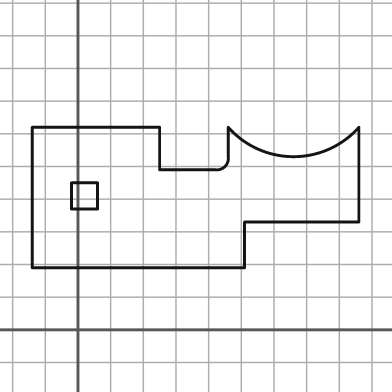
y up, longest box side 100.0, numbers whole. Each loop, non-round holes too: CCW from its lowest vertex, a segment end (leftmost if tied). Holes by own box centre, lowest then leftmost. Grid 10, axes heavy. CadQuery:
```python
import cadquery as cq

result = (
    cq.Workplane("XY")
    .moveTo(-14.0, 19.0)
    .lineTo(51.0, 19.0)
    .lineTo(51.0, 33.0)
    .lineTo(86.0, 33.0)
    .lineTo(86.0, 62.0)
    .threePointArc((66.0, 53.0), (46.0, 62.0))
    .lineTo(46.0, 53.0)
    .threePointArc((45.0, 50.0), (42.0, 49.0))
    .lineTo(25.0, 49.0)
    .lineTo(25.0, 62.0)
    .lineTo(-14.0, 62.0)
    .close()
    .moveTo(-2.0, 37.0)
    .lineTo(6.0, 37.0)
    .lineTo(6.0, 45.0)
    .lineTo(-2.0, 45.0)
    .close()
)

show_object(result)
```